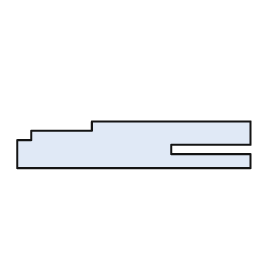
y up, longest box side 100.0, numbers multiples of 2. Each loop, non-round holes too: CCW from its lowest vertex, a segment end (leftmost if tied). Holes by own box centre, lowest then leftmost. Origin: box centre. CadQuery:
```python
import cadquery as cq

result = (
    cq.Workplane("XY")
    .moveTo(-50.0, -10.0)
    .lineTo(50.0, -10.0)
    .lineTo(50.0, -4.0)
    .lineTo(16.0, -4.0)
    .lineTo(16.0, 0.0)
    .lineTo(50.0, 0.0)
    .lineTo(50.0, 10.0)
    .lineTo(-18.0, 10.0)
    .lineTo(-18.0, 6.0)
    .lineTo(-44.0, 6.0)
    .lineTo(-44.0, 2.0)
    .lineTo(-50.0, 2.0)
    .close()
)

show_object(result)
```